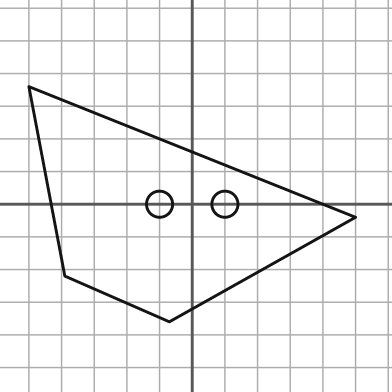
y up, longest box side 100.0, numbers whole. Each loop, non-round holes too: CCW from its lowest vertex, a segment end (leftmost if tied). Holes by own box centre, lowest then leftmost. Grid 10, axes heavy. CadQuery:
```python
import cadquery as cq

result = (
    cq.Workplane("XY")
    .moveTo(-7.0, -36.0)
    .lineTo(50.0, -4.0)
    .lineTo(-50.0, 36.0)
    .lineTo(-39.0, -22.0)
    .close()
    .moveTo(-10.0, 0.0)
    .circle(4.0)
    .moveTo(10.0, 0.0)
    .circle(4.0)
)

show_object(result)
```